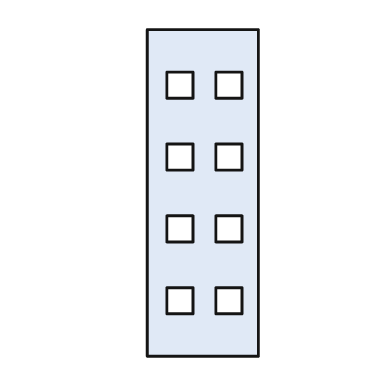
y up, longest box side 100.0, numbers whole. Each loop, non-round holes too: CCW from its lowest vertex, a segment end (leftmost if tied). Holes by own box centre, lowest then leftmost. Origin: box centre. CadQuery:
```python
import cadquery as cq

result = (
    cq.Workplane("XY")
    .moveTo(-17.0, -50.0)
    .lineTo(17.0, -50.0)
    .lineTo(17.0, 50.0)
    .lineTo(-17.0, 50.0)
    .close()
    .moveTo(-11.0, -37.0)
    .lineTo(-3.0, -37.0)
    .lineTo(-3.0, -29.0)
    .lineTo(-11.0, -29.0)
    .close()
    .moveTo(4.0, -37.0)
    .lineTo(12.0, -37.0)
    .lineTo(12.0, -29.0)
    .lineTo(4.0, -29.0)
    .close()
    .moveTo(-11.0, -15.0)
    .lineTo(-3.0, -15.0)
    .lineTo(-3.0, -7.0)
    .lineTo(-11.0, -7.0)
    .close()
    .moveTo(4.0, -15.0)
    .lineTo(12.0, -15.0)
    .lineTo(12.0, -7.0)
    .lineTo(4.0, -7.0)
    .close()
    .moveTo(-11.0, 7.0)
    .lineTo(-3.0, 7.0)
    .lineTo(-3.0, 15.0)
    .lineTo(-11.0, 15.0)
    .close()
    .moveTo(4.0, 7.0)
    .lineTo(12.0, 7.0)
    .lineTo(12.0, 15.0)
    .lineTo(4.0, 15.0)
    .close()
    .moveTo(-11.0, 29.0)
    .lineTo(-3.0, 29.0)
    .lineTo(-3.0, 37.0)
    .lineTo(-11.0, 37.0)
    .close()
    .moveTo(4.0, 29.0)
    .lineTo(12.0, 29.0)
    .lineTo(12.0, 37.0)
    .lineTo(4.0, 37.0)
    .close()
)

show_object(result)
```